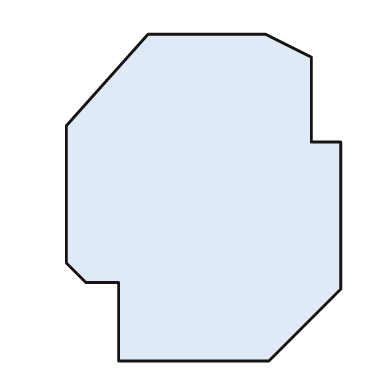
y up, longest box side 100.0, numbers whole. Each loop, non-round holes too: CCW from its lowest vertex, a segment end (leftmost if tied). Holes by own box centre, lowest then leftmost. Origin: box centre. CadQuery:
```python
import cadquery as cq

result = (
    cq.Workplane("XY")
    .moveTo(-26.0, -50.0)
    .lineTo(20.0, -50.0)
    .lineTo(42.0, -28.0)
    .lineTo(42.0, 17.0)
    .lineTo(33.0, 17.0)
    .lineTo(33.0, 43.0)
    .lineTo(19.0, 50.0)
    .lineTo(-17.0, 50.0)
    .lineTo(-42.0, 22.0)
    .lineTo(-42.0, -20.0)
    .lineTo(-36.0, -26.0)
    .lineTo(-26.0, -26.0)
    .close()
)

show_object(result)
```